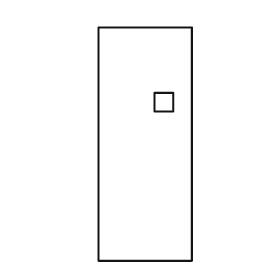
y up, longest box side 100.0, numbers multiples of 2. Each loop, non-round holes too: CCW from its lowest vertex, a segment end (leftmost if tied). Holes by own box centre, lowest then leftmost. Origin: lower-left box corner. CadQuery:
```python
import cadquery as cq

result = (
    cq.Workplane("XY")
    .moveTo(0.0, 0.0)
    .lineTo(40.0, 0.0)
    .lineTo(40.0, 100.0)
    .lineTo(0.0, 100.0)
    .close()
    .moveTo(24.0, 64.0)
    .lineTo(32.0, 64.0)
    .lineTo(32.0, 72.0)
    .lineTo(24.0, 72.0)
    .close()
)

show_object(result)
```